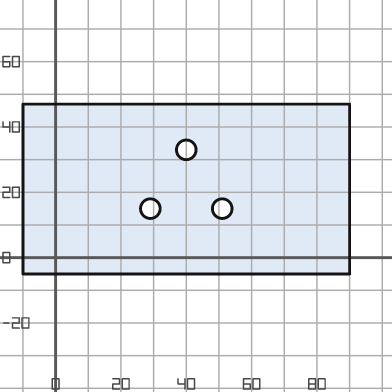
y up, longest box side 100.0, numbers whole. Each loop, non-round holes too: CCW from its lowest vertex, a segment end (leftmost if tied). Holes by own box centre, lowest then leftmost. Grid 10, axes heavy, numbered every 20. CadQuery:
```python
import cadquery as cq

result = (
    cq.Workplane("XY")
    .moveTo(-10.0, -5.0)
    .lineTo(90.0, -5.0)
    .lineTo(90.0, 47.0)
    .lineTo(-10.0, 47.0)
    .close()
    .moveTo(29.0, 15.0)
    .circle(3.0)
    .moveTo(51.0, 15.0)
    .circle(3.0)
    .moveTo(40.0, 33.0)
    .circle(3.0)
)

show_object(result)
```